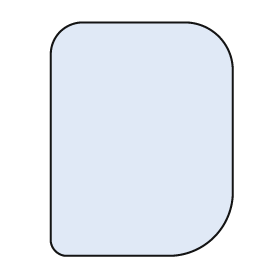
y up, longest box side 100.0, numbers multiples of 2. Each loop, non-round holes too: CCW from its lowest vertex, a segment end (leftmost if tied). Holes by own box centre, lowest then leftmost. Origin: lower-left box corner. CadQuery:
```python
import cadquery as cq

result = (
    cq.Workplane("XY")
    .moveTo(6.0, 0.0)
    .lineTo(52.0, 0.0)
    .threePointArc((70.0, 8.0), (78.0, 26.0))
    .lineTo(78.0, 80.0)
    .threePointArc((72.0, 94.0), (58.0, 100.0))
    .lineTo(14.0, 100.0)
    .threePointArc((4.0, 96.0), (0.0, 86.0))
    .lineTo(0.0, 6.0)
    .threePointArc((2.0, 2.0), (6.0, 0.0))
    .close()
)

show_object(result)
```